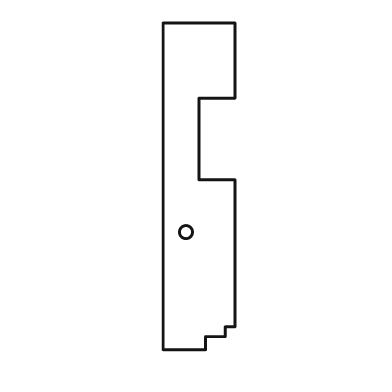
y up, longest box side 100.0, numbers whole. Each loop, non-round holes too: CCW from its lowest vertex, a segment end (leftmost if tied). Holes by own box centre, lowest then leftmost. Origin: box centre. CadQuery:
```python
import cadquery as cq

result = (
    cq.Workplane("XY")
    .moveTo(-11.0, -50.0)
    .lineTo(2.0, -50.0)
    .lineTo(2.0, -46.0)
    .lineTo(8.0, -46.0)
    .lineTo(8.0, -43.0)
    .lineTo(11.0, -43.0)
    .lineTo(11.0, 2.0)
    .lineTo(0.0, 2.0)
    .lineTo(0.0, 27.0)
    .lineTo(11.0, 27.0)
    .lineTo(11.0, 50.0)
    .lineTo(-11.0, 50.0)
    .close()
    .moveTo(-4.0, -14.0)
    .circle(2.0)
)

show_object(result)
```